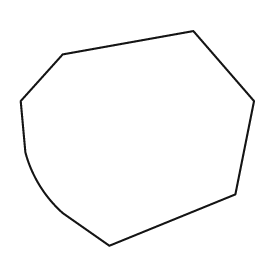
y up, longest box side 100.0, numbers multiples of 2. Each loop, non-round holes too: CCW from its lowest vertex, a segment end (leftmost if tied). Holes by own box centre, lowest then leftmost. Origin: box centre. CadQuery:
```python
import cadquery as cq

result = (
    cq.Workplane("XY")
    .moveTo(-12.0, -46.0)
    .lineTo(42.0, -24.0)
    .lineTo(50.0, 16.0)
    .lineTo(24.0, 46.0)
    .lineTo(-32.0, 36.0)
    .lineTo(-50.0, 16.0)
    .lineTo(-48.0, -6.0)
    .threePointArc((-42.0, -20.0), (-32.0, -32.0))
    .close()
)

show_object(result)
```